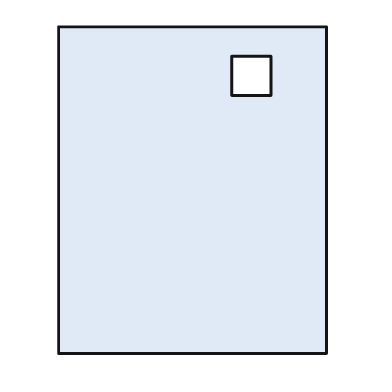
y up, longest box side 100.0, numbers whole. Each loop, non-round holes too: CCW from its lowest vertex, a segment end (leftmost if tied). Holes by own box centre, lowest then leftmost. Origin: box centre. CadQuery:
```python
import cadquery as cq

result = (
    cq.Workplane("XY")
    .moveTo(-41.0, -50.0)
    .lineTo(41.0, -50.0)
    .lineTo(41.0, 50.0)
    .lineTo(-41.0, 50.0)
    .close()
    .moveTo(12.0, 29.0)
    .lineTo(24.0, 29.0)
    .lineTo(24.0, 41.0)
    .lineTo(12.0, 41.0)
    .close()
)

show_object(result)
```